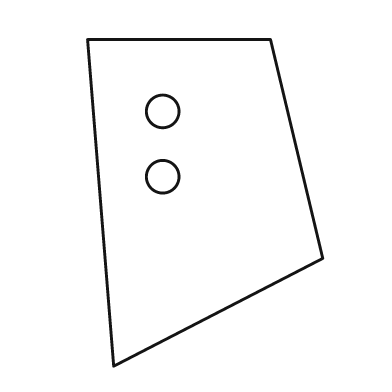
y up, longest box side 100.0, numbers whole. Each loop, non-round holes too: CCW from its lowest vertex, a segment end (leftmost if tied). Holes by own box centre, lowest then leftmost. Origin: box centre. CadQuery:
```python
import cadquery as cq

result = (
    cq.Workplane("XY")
    .moveTo(-28.0, -50.0)
    .lineTo(36.0, -17.0)
    .lineTo(20.0, 50.0)
    .lineTo(-36.0, 50.0)
    .close()
    .moveTo(-13.0, 8.0)
    .circle(5.0)
    .moveTo(-13.0, 28.0)
    .circle(5.0)
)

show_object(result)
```